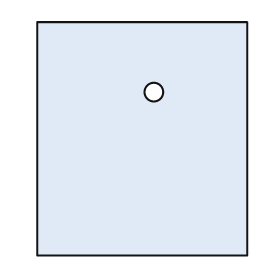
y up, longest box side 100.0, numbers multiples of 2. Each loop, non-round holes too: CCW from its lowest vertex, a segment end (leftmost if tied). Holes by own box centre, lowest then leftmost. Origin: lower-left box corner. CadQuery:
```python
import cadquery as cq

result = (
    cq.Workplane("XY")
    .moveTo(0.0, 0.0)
    .lineTo(90.0, 0.0)
    .lineTo(90.0, 100.0)
    .lineTo(0.0, 100.0)
    .close()
    .moveTo(50.0, 70.0)
    .circle(4.0)
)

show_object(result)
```